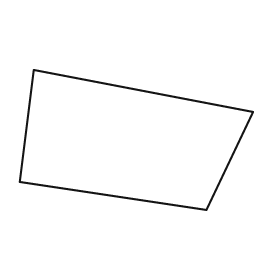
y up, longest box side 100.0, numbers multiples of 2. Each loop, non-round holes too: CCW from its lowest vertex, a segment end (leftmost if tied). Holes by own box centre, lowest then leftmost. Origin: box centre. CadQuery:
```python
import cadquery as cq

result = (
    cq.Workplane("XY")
    .moveTo(30.0, -30.0)
    .lineTo(50.0, 12.0)
    .lineTo(-44.0, 30.0)
    .lineTo(-50.0, -18.0)
    .close()
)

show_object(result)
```